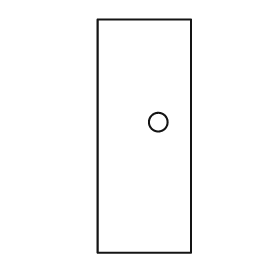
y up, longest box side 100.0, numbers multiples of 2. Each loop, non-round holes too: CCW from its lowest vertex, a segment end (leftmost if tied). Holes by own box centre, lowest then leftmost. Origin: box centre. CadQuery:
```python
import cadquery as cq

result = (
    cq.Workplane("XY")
    .moveTo(-20.0, -50.0)
    .lineTo(20.0, -50.0)
    .lineTo(20.0, 50.0)
    .lineTo(-20.0, 50.0)
    .close()
    .moveTo(6.0, 6.0)
    .circle(4.0)
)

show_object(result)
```